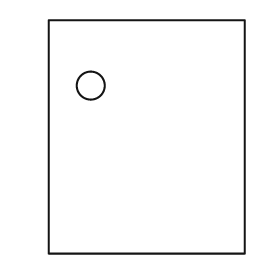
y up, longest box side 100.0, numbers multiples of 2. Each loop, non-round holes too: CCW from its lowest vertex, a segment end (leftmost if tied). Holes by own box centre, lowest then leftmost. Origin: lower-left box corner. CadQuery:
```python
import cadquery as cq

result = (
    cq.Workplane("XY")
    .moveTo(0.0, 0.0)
    .lineTo(84.0, 0.0)
    .lineTo(84.0, 100.0)
    .lineTo(0.0, 100.0)
    .close()
    .moveTo(18.0, 72.0)
    .circle(6.0)
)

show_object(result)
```